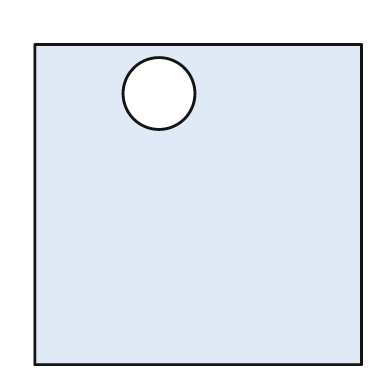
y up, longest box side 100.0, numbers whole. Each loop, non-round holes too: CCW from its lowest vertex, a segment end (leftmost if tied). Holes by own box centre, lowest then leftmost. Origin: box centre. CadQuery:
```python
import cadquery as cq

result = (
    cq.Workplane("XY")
    .moveTo(-50.0, -49.0)
    .lineTo(50.0, -49.0)
    .lineTo(50.0, 49.0)
    .lineTo(-50.0, 49.0)
    .close()
    .moveTo(-12.0, 34.0)
    .circle(11.0)
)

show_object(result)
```